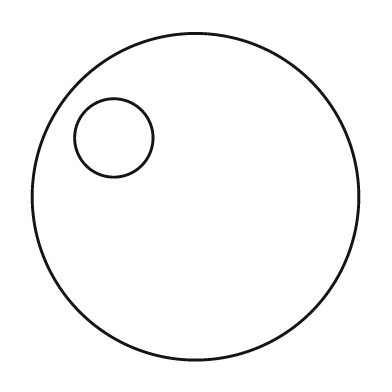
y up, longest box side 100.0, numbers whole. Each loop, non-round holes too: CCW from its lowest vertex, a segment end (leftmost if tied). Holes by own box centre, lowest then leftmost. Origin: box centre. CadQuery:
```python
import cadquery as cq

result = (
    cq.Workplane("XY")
    .moveTo(0.0, 0.0)
    .circle(50.0)
    .moveTo(-25.0, 18.0)
    .circle(12.0)
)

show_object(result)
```